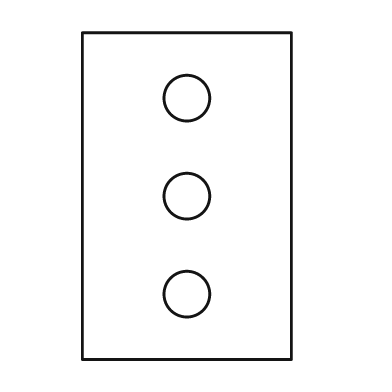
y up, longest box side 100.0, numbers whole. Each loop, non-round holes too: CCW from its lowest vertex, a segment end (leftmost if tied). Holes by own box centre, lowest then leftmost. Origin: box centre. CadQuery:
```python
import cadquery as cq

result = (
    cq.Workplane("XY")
    .moveTo(-32.0, -50.0)
    .lineTo(32.0, -50.0)
    .lineTo(32.0, 50.0)
    .lineTo(-32.0, 50.0)
    .close()
    .moveTo(0.0, -30.0)
    .circle(7.0)
    .moveTo(0.0, 0.0)
    .circle(7.0)
    .moveTo(0.0, 30.0)
    .circle(7.0)
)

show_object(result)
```